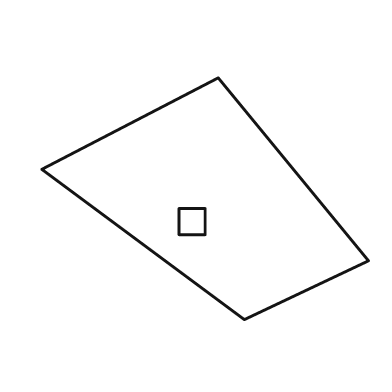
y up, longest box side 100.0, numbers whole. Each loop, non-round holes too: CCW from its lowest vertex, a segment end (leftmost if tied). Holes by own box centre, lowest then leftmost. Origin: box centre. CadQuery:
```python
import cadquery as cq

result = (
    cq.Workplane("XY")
    .moveTo(12.0, -37.0)
    .lineTo(50.0, -19.0)
    .lineTo(4.0, 37.0)
    .lineTo(-50.0, 9.0)
    .close()
    .moveTo(-8.0, -11.0)
    .lineTo(0.0, -11.0)
    .lineTo(0.0, -3.0)
    .lineTo(-8.0, -3.0)
    .close()
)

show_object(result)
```